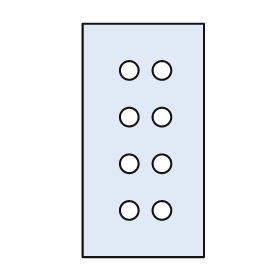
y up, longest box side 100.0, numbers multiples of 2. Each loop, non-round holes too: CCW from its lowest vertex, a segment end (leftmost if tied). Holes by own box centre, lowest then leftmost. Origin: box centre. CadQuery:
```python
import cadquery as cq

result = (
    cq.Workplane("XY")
    .moveTo(-26.0, -50.0)
    .lineTo(26.0, -50.0)
    .lineTo(26.0, 50.0)
    .lineTo(-26.0, 50.0)
    .close()
    .moveTo(-6.0, -30.0)
    .circle(4.0)
    .moveTo(8.0, -30.0)
    .circle(4.0)
    .moveTo(-6.0, -10.0)
    .circle(4.0)
    .moveTo(8.0, -10.0)
    .circle(4.0)
    .moveTo(-6.0, 10.0)
    .circle(4.0)
    .moveTo(8.0, 10.0)
    .circle(4.0)
    .moveTo(-6.0, 30.0)
    .circle(4.0)
    .moveTo(8.0, 30.0)
    .circle(4.0)
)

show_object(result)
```